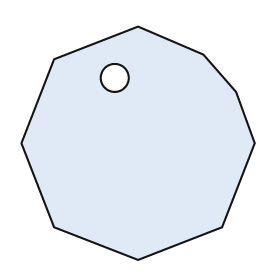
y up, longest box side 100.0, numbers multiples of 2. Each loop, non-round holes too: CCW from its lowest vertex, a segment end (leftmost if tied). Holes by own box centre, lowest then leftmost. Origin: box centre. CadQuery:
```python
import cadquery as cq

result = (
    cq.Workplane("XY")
    .moveTo(0.0, -50.0)
    .lineTo(36.0, -36.0)
    .lineTo(50.0, 0.0)
    .lineTo(42.0, 22.0)
    .lineTo(28.0, 38.0)
    .lineTo(0.0, 50.0)
    .lineTo(-36.0, 36.0)
    .lineTo(-50.0, 0.0)
    .lineTo(-36.0, -36.0)
    .close()
    .moveTo(-10.0, 28.0)
    .circle(6.0)
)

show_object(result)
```